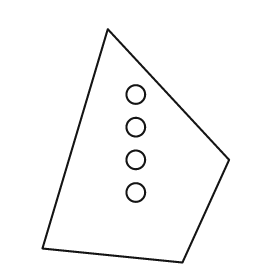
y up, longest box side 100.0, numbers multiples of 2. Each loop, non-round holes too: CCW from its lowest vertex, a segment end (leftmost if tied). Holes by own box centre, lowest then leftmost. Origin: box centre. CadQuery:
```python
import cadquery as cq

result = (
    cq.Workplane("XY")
    .moveTo(20.0, -50.0)
    .lineTo(40.0, -6.0)
    .lineTo(-12.0, 50.0)
    .lineTo(-40.0, -44.0)
    .close()
    .moveTo(0.0, -20.0)
    .circle(4.0)
    .moveTo(0.0, -6.0)
    .circle(4.0)
    .moveTo(0.0, 8.0)
    .circle(4.0)
    .moveTo(0.0, 22.0)
    .circle(4.0)
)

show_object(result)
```